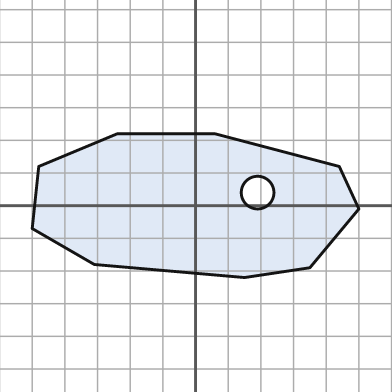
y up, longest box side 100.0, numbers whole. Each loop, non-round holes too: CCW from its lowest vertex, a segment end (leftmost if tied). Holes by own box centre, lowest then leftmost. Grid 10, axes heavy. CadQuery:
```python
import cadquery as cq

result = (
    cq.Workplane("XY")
    .moveTo(15.0, -22.0)
    .lineTo(35.0, -19.0)
    .lineTo(50.0, -1.0)
    .lineTo(44.0, 12.0)
    .lineTo(6.0, 22.0)
    .lineTo(-24.0, 22.0)
    .lineTo(-48.0, 12.0)
    .lineTo(-50.0, -7.0)
    .lineTo(-31.0, -18.0)
    .close()
    .moveTo(19.0, 4.0)
    .circle(5.0)
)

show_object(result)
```